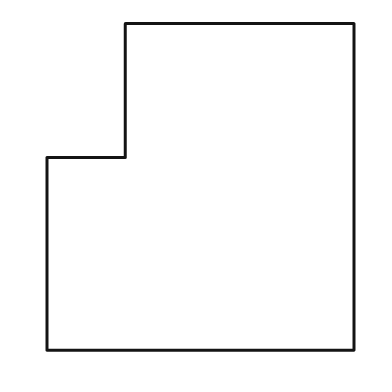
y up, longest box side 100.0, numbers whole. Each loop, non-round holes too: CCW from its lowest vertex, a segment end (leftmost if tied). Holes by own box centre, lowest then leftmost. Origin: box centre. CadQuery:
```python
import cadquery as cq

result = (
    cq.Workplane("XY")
    .moveTo(-47.0, -50.0)
    .lineTo(47.0, -50.0)
    .lineTo(47.0, 50.0)
    .lineTo(-23.0, 50.0)
    .lineTo(-23.0, 9.0)
    .lineTo(-47.0, 9.0)
    .close()
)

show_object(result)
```